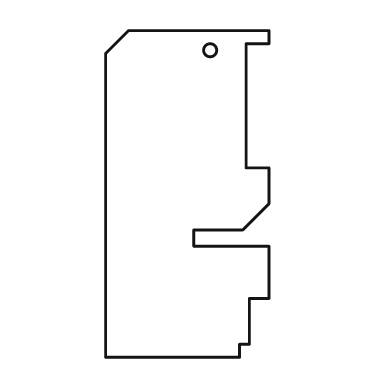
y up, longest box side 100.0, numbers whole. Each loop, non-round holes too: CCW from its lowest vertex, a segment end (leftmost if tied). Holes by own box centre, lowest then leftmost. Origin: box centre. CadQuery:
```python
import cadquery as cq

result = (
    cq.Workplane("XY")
    .moveTo(-25.0, -50.0)
    .lineTo(16.0, -50.0)
    .lineTo(16.0, -46.0)
    .lineTo(19.0, -46.0)
    .lineTo(19.0, -32.0)
    .lineTo(25.0, -32.0)
    .lineTo(25.0, -16.0)
    .lineTo(2.0, -16.0)
    .lineTo(2.0, -11.0)
    .lineTo(17.0, -11.0)
    .lineTo(25.0, -3.0)
    .lineTo(25.0, 8.0)
    .lineTo(18.0, 8.0)
    .lineTo(18.0, 46.0)
    .lineTo(25.0, 46.0)
    .lineTo(25.0, 50.0)
    .lineTo(-18.0, 50.0)
    .lineTo(-25.0, 43.0)
    .close()
    .moveTo(7.0, 44.0)
    .circle(2.0)
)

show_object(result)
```